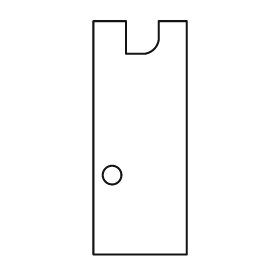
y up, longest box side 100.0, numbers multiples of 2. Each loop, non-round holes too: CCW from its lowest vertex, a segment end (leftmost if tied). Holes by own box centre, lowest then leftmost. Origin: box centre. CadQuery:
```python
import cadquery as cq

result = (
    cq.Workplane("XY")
    .moveTo(-20.0, -50.0)
    .lineTo(20.0, -50.0)
    .lineTo(20.0, 50.0)
    .lineTo(8.0, 50.0)
    .lineTo(8.0, 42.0)
    .threePointArc((6.0, 38.0), (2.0, 36.0))
    .lineTo(-6.0, 36.0)
    .lineTo(-6.0, 50.0)
    .lineTo(-20.0, 50.0)
    .close()
    .moveTo(-12.0, -16.0)
    .circle(4.0)
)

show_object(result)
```